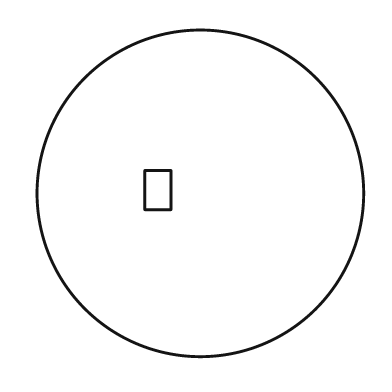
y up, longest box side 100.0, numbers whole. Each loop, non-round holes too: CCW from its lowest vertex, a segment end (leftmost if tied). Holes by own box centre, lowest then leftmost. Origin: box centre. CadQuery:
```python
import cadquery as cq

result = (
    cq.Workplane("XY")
    .moveTo(0.0, 0.0)
    .circle(50.0)
    .moveTo(-17.0, -5.0)
    .lineTo(-9.0, -5.0)
    .lineTo(-9.0, 7.0)
    .lineTo(-17.0, 7.0)
    .close()
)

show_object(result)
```